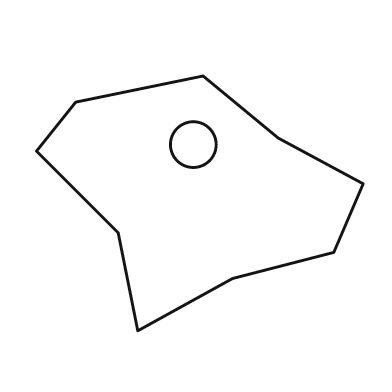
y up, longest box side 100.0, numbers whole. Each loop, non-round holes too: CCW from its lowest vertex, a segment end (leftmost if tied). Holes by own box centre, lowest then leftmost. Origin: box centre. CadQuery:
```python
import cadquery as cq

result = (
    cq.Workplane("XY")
    .moveTo(-19.0, -39.0)
    .lineTo(10.0, -23.0)
    .lineTo(41.0, -15.0)
    .lineTo(50.0, 6.0)
    .lineTo(24.0, 20.0)
    .lineTo(1.0, 39.0)
    .lineTo(-38.0, 31.0)
    .lineTo(-50.0, 16.0)
    .lineTo(-25.0, -9.0)
    .close()
    .moveTo(-2.0, 18.0)
    .circle(7.0)
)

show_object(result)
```